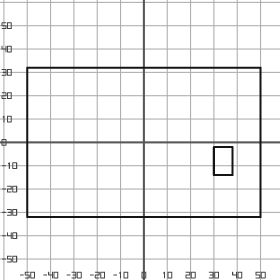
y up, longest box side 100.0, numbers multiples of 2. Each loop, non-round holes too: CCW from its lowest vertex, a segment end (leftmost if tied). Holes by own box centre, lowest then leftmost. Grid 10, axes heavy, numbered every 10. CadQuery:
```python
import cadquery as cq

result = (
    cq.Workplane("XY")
    .moveTo(-50.0, -32.0)
    .lineTo(50.0, -32.0)
    .lineTo(50.0, 32.0)
    .lineTo(-50.0, 32.0)
    .close()
    .moveTo(30.0, -14.0)
    .lineTo(38.0, -14.0)
    .lineTo(38.0, -2.0)
    .lineTo(30.0, -2.0)
    .close()
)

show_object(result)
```